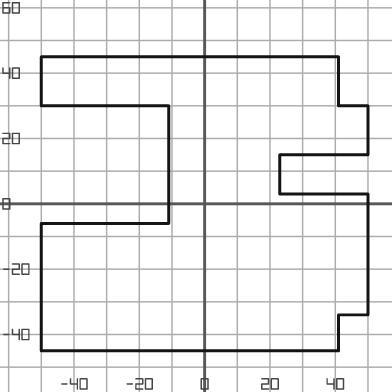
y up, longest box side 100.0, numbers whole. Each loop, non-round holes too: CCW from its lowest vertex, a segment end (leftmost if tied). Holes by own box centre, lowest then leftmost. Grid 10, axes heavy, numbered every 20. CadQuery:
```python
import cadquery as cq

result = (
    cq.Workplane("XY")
    .moveTo(-50.0, -45.0)
    .lineTo(41.0, -45.0)
    .lineTo(41.0, -34.0)
    .lineTo(50.0, -34.0)
    .lineTo(50.0, 3.0)
    .lineTo(23.0, 3.0)
    .lineTo(23.0, 15.0)
    .lineTo(50.0, 15.0)
    .lineTo(50.0, 30.0)
    .lineTo(41.0, 30.0)
    .lineTo(41.0, 45.0)
    .lineTo(-50.0, 45.0)
    .lineTo(-50.0, 30.0)
    .lineTo(-11.0, 30.0)
    .lineTo(-11.0, -6.0)
    .lineTo(-50.0, -6.0)
    .close()
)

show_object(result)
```